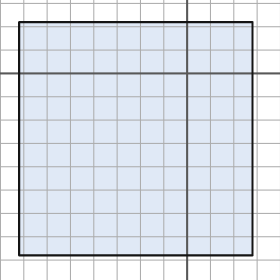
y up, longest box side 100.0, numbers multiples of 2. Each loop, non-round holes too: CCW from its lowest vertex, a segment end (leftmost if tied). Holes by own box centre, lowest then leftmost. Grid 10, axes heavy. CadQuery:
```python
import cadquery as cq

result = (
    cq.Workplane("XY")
    .moveTo(-72.0, -78.0)
    .lineTo(28.0, -78.0)
    .lineTo(28.0, 22.0)
    .lineTo(-72.0, 22.0)
    .close()
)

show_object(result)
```